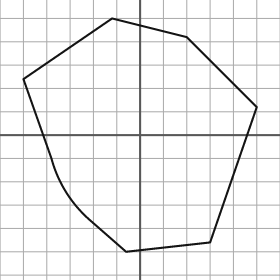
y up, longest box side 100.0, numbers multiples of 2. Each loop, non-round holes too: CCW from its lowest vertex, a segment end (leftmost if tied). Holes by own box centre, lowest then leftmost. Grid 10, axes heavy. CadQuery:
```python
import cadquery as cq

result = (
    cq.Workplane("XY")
    .moveTo(-6.0, -50.0)
    .lineTo(30.0, -46.0)
    .lineTo(50.0, 12.0)
    .lineTo(20.0, 42.0)
    .lineTo(-12.0, 50.0)
    .lineTo(-50.0, 24.0)
    .lineTo(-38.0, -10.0)
    .threePointArc((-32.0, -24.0), (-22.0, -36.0))
    .close()
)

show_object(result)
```